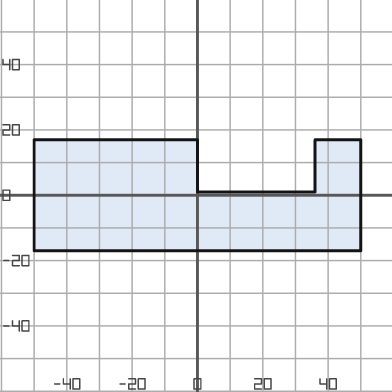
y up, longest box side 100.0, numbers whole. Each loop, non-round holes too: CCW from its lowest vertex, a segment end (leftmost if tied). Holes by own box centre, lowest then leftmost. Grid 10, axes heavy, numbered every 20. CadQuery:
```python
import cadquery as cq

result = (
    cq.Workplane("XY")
    .moveTo(-50.0, -17.0)
    .lineTo(50.0, -17.0)
    .lineTo(50.0, 17.0)
    .lineTo(36.0, 17.0)
    .lineTo(36.0, 1.0)
    .lineTo(0.0, 1.0)
    .lineTo(0.0, 17.0)
    .lineTo(-50.0, 17.0)
    .close()
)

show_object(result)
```